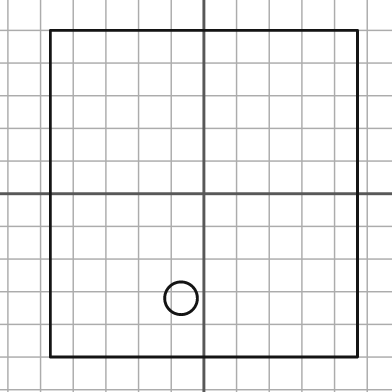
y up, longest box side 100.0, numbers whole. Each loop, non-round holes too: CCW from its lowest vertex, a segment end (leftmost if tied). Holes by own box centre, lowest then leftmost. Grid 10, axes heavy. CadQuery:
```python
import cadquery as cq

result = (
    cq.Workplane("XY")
    .moveTo(-47.0, -50.0)
    .lineTo(47.0, -50.0)
    .lineTo(47.0, 50.0)
    .lineTo(-47.0, 50.0)
    .close()
    .moveTo(-7.0, -32.0)
    .circle(5.0)
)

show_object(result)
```